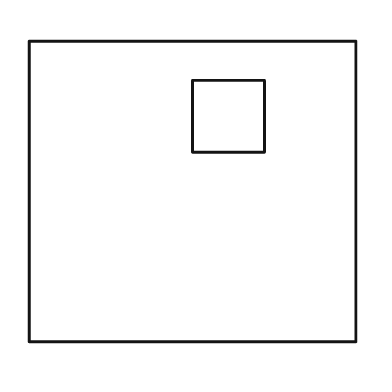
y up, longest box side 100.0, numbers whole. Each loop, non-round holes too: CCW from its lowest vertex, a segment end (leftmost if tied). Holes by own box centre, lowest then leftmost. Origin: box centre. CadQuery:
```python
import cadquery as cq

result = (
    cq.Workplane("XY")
    .moveTo(-50.0, -46.0)
    .lineTo(50.0, -46.0)
    .lineTo(50.0, 46.0)
    .lineTo(-50.0, 46.0)
    .close()
    .moveTo(0.0, 12.0)
    .lineTo(22.0, 12.0)
    .lineTo(22.0, 34.0)
    .lineTo(0.0, 34.0)
    .close()
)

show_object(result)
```